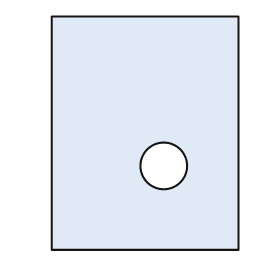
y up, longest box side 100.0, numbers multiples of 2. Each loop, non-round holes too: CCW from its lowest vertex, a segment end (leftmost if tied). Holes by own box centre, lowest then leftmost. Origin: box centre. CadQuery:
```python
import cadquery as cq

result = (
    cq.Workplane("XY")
    .moveTo(-40.0, -50.0)
    .lineTo(40.0, -50.0)
    .lineTo(40.0, 50.0)
    .lineTo(-40.0, 50.0)
    .close()
    .moveTo(8.0, -14.0)
    .circle(10.0)
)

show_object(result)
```